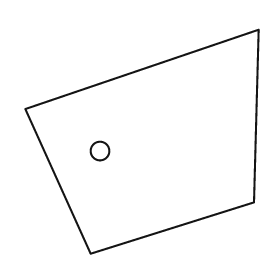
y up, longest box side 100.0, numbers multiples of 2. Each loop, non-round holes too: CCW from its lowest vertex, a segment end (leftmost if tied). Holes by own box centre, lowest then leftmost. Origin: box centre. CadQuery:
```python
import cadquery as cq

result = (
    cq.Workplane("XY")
    .moveTo(-22.0, -48.0)
    .lineTo(48.0, -26.0)
    .lineTo(50.0, 48.0)
    .lineTo(-50.0, 14.0)
    .close()
    .moveTo(-18.0, -4.0)
    .circle(4.0)
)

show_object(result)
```